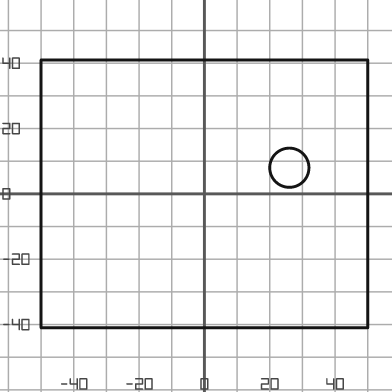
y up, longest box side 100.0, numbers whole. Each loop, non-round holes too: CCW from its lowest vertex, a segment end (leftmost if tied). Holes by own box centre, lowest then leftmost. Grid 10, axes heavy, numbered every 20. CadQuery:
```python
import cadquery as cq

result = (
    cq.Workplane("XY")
    .moveTo(-50.0, -41.0)
    .lineTo(50.0, -41.0)
    .lineTo(50.0, 41.0)
    .lineTo(-50.0, 41.0)
    .close()
    .moveTo(26.0, 8.0)
    .circle(6.0)
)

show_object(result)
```